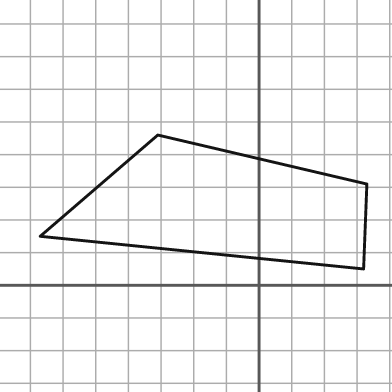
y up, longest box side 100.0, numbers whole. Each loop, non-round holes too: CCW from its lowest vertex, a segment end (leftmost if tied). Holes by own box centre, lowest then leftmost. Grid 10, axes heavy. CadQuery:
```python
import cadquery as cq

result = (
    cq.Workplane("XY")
    .moveTo(32.0, 5.0)
    .lineTo(33.0, 31.0)
    .lineTo(-31.0, 46.0)
    .lineTo(-67.0, 15.0)
    .close()
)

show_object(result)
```